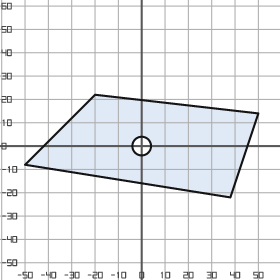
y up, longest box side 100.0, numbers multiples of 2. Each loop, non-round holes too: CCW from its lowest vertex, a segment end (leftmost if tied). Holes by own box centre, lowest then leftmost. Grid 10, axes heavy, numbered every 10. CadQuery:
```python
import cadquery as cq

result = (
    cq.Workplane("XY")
    .moveTo(38.0, -22.0)
    .lineTo(50.0, 14.0)
    .lineTo(-20.0, 22.0)
    .lineTo(-50.0, -8.0)
    .close()
    .moveTo(0.0, 0.0)
    .circle(4.0)
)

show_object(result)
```